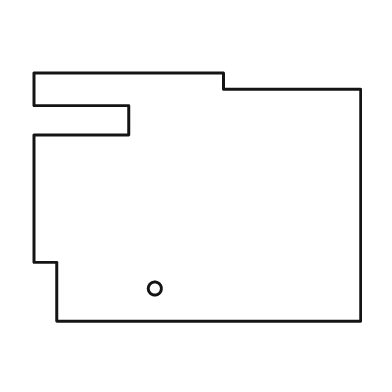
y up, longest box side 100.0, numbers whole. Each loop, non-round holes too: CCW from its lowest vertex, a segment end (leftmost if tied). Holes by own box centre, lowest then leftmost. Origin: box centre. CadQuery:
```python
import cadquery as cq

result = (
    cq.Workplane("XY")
    .moveTo(-43.0, -38.0)
    .lineTo(50.0, -38.0)
    .lineTo(50.0, 33.0)
    .lineTo(8.0, 33.0)
    .lineTo(8.0, 38.0)
    .lineTo(-50.0, 38.0)
    .lineTo(-50.0, 28.0)
    .lineTo(-21.0, 28.0)
    .lineTo(-21.0, 19.0)
    .lineTo(-50.0, 19.0)
    .lineTo(-50.0, -20.0)
    .lineTo(-43.0, -20.0)
    .close()
    .moveTo(-13.0, -28.0)
    .circle(2.0)
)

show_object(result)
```